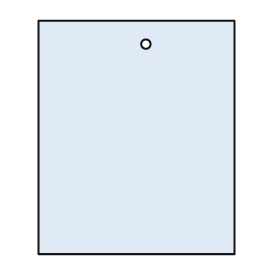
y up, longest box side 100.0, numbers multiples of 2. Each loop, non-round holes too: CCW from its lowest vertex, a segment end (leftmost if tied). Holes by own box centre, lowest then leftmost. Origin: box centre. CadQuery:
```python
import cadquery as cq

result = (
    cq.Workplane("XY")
    .moveTo(-42.0, -50.0)
    .lineTo(42.0, -50.0)
    .lineTo(42.0, 50.0)
    .lineTo(-42.0, 50.0)
    .close()
    .moveTo(4.0, 40.0)
    .circle(2.0)
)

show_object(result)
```